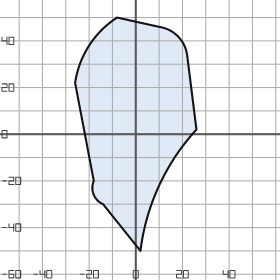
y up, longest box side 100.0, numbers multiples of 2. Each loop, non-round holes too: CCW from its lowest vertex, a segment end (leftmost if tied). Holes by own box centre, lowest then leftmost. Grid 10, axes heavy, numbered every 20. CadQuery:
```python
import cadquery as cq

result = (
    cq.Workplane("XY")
    .moveTo(2.0, -50.0)
    .threePointArc((10.0, -22.0), (26.0, 2.0))
    .lineTo(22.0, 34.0)
    .threePointArc((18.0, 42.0), (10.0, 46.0))
    .lineTo(-8.0, 50.0)
    .threePointArc((-20.0, 38.0), (-26.0, 22.0))
    .lineTo(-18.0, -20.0)
    .threePointArc((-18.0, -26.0), (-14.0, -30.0))
    .close()
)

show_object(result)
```